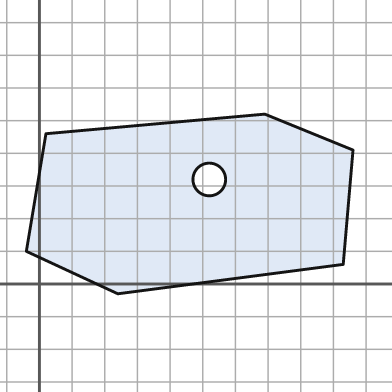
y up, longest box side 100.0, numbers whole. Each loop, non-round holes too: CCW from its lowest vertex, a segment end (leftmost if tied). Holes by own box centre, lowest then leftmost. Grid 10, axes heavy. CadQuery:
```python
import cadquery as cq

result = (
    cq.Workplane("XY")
    .moveTo(24.0, -3.0)
    .lineTo(93.0, 6.0)
    .lineTo(96.0, 41.0)
    .lineTo(69.0, 52.0)
    .lineTo(2.0, 46.0)
    .lineTo(-4.0, 10.0)
    .close()
    .moveTo(52.0, 32.0)
    .circle(5.0)
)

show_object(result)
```